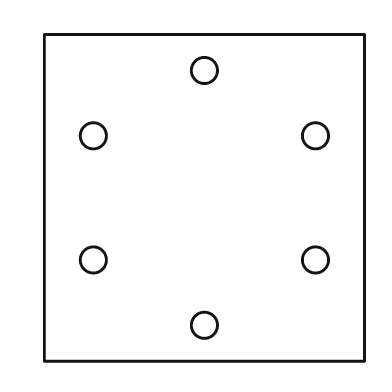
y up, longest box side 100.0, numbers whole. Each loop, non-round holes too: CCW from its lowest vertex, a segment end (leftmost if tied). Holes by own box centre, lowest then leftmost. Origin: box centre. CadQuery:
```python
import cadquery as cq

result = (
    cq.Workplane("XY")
    .moveTo(-49.0, -50.0)
    .lineTo(49.0, -50.0)
    .lineTo(49.0, 50.0)
    .lineTo(-49.0, 50.0)
    .close()
    .moveTo(0.0, -39.0)
    .circle(4.0)
    .moveTo(-34.0, -19.0)
    .circle(4.0)
    .moveTo(34.0, -19.0)
    .circle(4.0)
    .moveTo(-34.0, 19.0)
    .circle(4.0)
    .moveTo(34.0, 19.0)
    .circle(4.0)
    .moveTo(0.0, 39.0)
    .circle(4.0)
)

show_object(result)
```